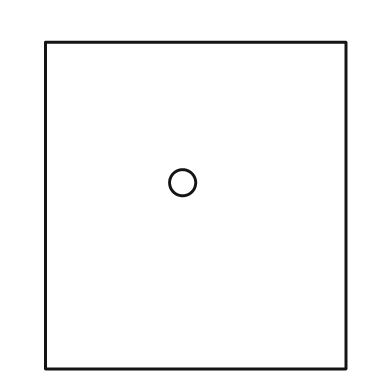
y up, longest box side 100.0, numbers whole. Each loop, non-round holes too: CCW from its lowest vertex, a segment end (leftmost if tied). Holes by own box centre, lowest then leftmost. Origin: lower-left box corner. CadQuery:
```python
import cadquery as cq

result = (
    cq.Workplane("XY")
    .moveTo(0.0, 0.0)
    .lineTo(92.0, 0.0)
    .lineTo(92.0, 100.0)
    .lineTo(0.0, 100.0)
    .close()
    .moveTo(42.0, 57.0)
    .circle(4.0)
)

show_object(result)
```